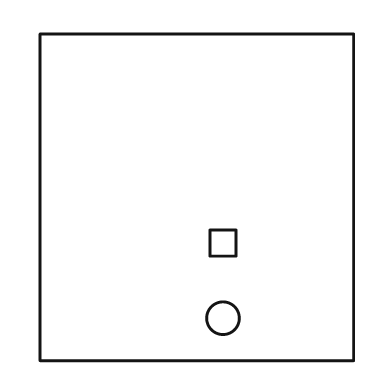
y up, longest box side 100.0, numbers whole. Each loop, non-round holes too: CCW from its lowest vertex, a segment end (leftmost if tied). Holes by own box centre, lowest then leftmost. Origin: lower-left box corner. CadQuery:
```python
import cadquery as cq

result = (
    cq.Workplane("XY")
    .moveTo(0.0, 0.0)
    .lineTo(96.0, 0.0)
    .lineTo(96.0, 100.0)
    .lineTo(0.0, 100.0)
    .close()
    .moveTo(56.0, 13.0)
    .circle(5.0)
    .moveTo(52.0, 32.0)
    .lineTo(60.0, 32.0)
    .lineTo(60.0, 40.0)
    .lineTo(52.0, 40.0)
    .close()
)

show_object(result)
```